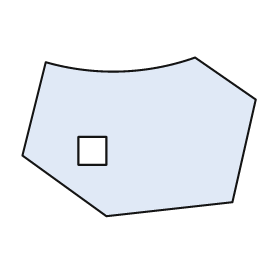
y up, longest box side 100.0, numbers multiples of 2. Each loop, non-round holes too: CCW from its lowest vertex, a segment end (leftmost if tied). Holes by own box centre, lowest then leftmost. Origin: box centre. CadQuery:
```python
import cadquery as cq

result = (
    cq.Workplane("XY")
    .moveTo(-14.0, -34.0)
    .lineTo(40.0, -28.0)
    .lineTo(50.0, 16.0)
    .lineTo(24.0, 34.0)
    .threePointArc((-8.0, 28.0), (-40.0, 32.0))
    .lineTo(-50.0, -8.0)
    .close()
    .moveTo(-26.0, -12.0)
    .lineTo(-14.0, -12.0)
    .lineTo(-14.0, 0.0)
    .lineTo(-26.0, 0.0)
    .close()
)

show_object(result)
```